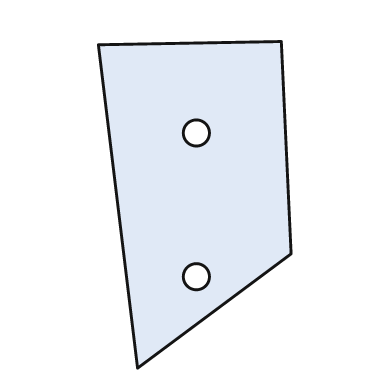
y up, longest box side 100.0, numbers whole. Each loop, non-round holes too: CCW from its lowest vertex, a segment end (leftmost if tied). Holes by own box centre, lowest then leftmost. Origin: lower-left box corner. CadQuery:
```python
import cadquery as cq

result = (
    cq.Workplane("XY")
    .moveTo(12.0, 0.0)
    .lineTo(59.0, 35.0)
    .lineTo(56.0, 100.0)
    .lineTo(0.0, 99.0)
    .close()
    .moveTo(30.0, 28.0)
    .circle(4.0)
    .moveTo(30.0, 72.0)
    .circle(4.0)
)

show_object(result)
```